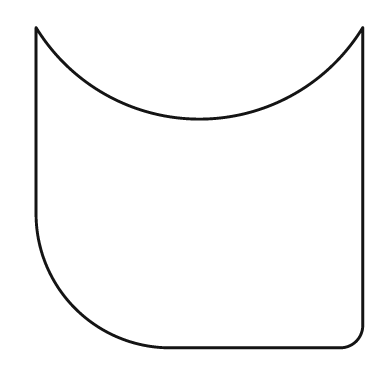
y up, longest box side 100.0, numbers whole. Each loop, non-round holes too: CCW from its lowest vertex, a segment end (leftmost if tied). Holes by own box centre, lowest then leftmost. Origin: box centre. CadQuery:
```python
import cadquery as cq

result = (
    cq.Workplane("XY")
    .moveTo(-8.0, -49.0)
    .lineTo(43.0, -49.0)
    .threePointArc((48.0, -47.0), (50.0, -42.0))
    .lineTo(50.0, 49.0)
    .threePointArc((0.0, 21.0), (-50.0, 49.0))
    .lineTo(-50.0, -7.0)
    .threePointArc((-38.0, -37.0), (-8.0, -49.0))
    .close()
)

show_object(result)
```